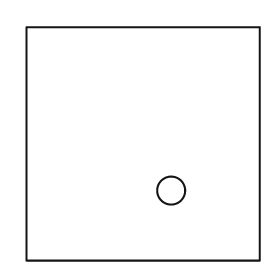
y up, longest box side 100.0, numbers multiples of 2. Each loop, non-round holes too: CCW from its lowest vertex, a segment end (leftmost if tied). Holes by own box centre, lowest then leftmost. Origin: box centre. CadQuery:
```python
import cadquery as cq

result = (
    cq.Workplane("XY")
    .moveTo(-50.0, -50.0)
    .lineTo(50.0, -50.0)
    .lineTo(50.0, 50.0)
    .lineTo(-50.0, 50.0)
    .close()
    .moveTo(12.0, -20.0)
    .circle(6.0)
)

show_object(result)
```